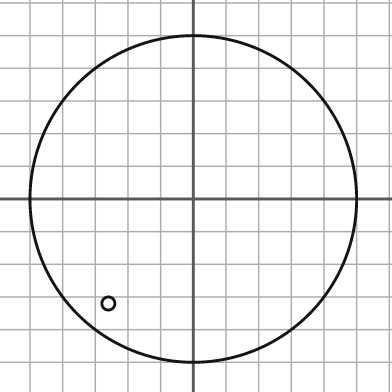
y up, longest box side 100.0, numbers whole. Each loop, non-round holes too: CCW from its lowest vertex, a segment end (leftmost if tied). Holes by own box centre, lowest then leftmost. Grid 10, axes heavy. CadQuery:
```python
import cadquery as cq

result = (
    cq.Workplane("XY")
    .moveTo(0.0, 0.0)
    .circle(50.0)
    .moveTo(-26.0, -32.0)
    .circle(2.0)
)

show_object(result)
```